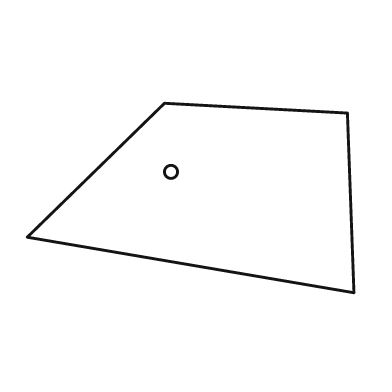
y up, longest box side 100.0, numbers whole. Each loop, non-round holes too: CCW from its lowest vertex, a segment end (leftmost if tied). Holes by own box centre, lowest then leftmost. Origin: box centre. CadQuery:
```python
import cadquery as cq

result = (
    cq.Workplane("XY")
    .moveTo(50.0, -29.0)
    .lineTo(48.0, 26.0)
    .lineTo(-8.0, 29.0)
    .lineTo(-50.0, -12.0)
    .close()
    .moveTo(-6.0, 8.0)
    .circle(2.0)
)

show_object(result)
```